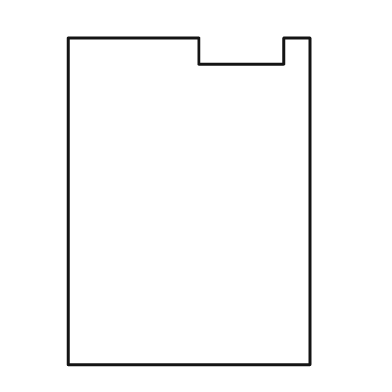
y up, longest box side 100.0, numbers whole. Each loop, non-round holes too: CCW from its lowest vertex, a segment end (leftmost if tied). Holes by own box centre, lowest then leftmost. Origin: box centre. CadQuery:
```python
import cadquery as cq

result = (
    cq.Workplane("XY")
    .moveTo(-37.0, -50.0)
    .lineTo(37.0, -50.0)
    .lineTo(37.0, 50.0)
    .lineTo(29.0, 50.0)
    .lineTo(29.0, 42.0)
    .lineTo(3.0, 42.0)
    .lineTo(3.0, 50.0)
    .lineTo(-37.0, 50.0)
    .close()
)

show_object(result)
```